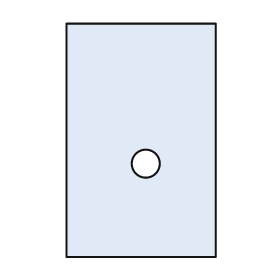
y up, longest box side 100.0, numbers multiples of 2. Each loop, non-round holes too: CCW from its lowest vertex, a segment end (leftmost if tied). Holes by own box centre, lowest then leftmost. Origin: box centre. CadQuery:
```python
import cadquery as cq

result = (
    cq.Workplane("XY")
    .moveTo(-32.0, -50.0)
    .lineTo(32.0, -50.0)
    .lineTo(32.0, 50.0)
    .lineTo(-32.0, 50.0)
    .close()
    .moveTo(2.0, -10.0)
    .circle(6.0)
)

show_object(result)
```